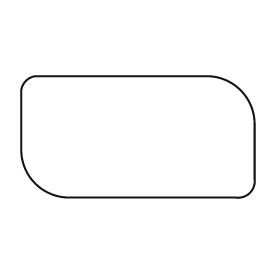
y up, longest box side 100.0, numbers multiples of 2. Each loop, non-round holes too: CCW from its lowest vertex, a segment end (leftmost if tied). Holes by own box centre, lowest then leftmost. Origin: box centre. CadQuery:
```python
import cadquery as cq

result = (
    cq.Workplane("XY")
    .moveTo(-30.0, -26.0)
    .lineTo(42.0, -26.0)
    .threePointArc((48.0, -24.0), (50.0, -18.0))
    .lineTo(50.0, 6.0)
    .threePointArc((44.0, 20.0), (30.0, 26.0))
    .lineTo(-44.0, 26.0)
    .threePointArc((-48.0, 24.0), (-50.0, 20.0))
    .lineTo(-50.0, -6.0)
    .threePointArc((-44.0, -20.0), (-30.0, -26.0))
    .close()
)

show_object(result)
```